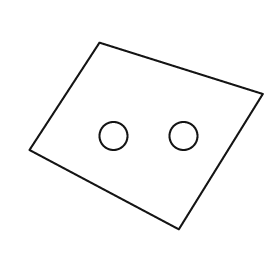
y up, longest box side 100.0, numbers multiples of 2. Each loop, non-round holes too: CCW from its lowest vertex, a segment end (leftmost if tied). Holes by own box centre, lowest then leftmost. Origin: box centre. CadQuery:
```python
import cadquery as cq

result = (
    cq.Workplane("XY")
    .moveTo(14.0, -40.0)
    .lineTo(50.0, 18.0)
    .lineTo(-20.0, 40.0)
    .lineTo(-50.0, -6.0)
    .close()
    .moveTo(-14.0, 0.0)
    .circle(6.0)
    .moveTo(16.0, 0.0)
    .circle(6.0)
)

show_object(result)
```